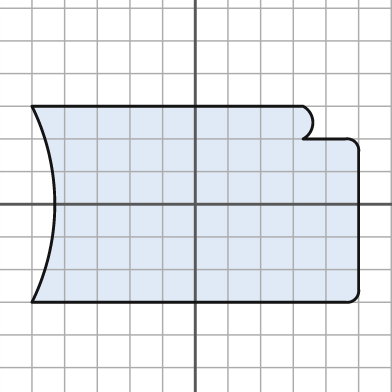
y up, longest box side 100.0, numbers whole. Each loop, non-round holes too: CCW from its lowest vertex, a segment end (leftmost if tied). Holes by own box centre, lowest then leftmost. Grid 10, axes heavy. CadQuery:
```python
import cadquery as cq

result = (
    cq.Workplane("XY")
    .moveTo(-50.0, -30.0)
    .lineTo(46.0, -30.0)
    .threePointArc((49.0, -29.0), (50.0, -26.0))
    .lineTo(50.0, 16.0)
    .threePointArc((49.0, 19.0), (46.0, 20.0))
    .lineTo(33.0, 20.0)
    .threePointArc((36.0, 25.0), (33.0, 30.0))
    .lineTo(-50.0, 30.0)
    .threePointArc((-43.0, 0.0), (-50.0, -30.0))
    .close()
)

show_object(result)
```